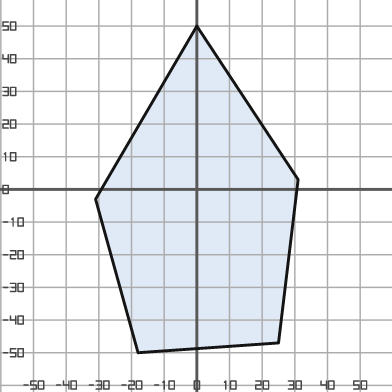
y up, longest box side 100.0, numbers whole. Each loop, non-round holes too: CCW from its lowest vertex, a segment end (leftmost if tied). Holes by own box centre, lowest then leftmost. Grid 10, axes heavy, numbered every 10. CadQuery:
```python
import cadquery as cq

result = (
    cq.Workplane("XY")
    .moveTo(-18.0, -50.0)
    .lineTo(25.0, -47.0)
    .lineTo(31.0, 3.0)
    .lineTo(0.0, 50.0)
    .lineTo(-31.0, -3.0)
    .close()
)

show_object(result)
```